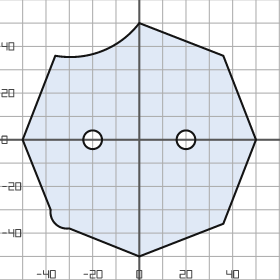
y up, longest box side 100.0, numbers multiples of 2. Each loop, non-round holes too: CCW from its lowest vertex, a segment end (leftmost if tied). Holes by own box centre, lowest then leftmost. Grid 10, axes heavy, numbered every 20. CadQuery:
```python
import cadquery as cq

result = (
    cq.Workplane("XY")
    .moveTo(0.0, -50.0)
    .lineTo(36.0, -36.0)
    .lineTo(50.0, 0.0)
    .lineTo(36.0, 36.0)
    .lineTo(0.0, 50.0)
    .threePointArc((-16.0, 38.0), (-36.0, 36.0))
    .lineTo(-50.0, 0.0)
    .lineTo(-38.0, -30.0)
    .threePointArc((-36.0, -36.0), (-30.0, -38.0))
    .close()
    .moveTo(-20.0, 0.0)
    .circle(4.0)
    .moveTo(20.0, 0.0)
    .circle(4.0)
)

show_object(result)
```